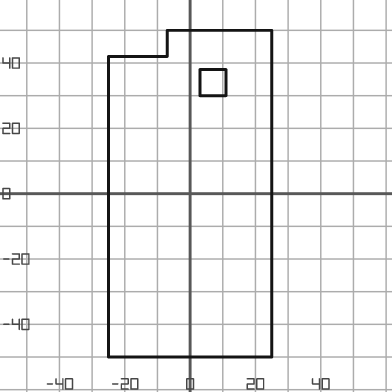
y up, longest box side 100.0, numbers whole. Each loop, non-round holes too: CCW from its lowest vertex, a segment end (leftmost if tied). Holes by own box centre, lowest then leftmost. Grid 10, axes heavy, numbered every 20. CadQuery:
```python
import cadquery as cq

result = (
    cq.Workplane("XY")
    .moveTo(-25.0, -50.0)
    .lineTo(25.0, -50.0)
    .lineTo(25.0, 50.0)
    .lineTo(-7.0, 50.0)
    .lineTo(-7.0, 42.0)
    .lineTo(-25.0, 42.0)
    .close()
    .moveTo(3.0, 30.0)
    .lineTo(11.0, 30.0)
    .lineTo(11.0, 38.0)
    .lineTo(3.0, 38.0)
    .close()
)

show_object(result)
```